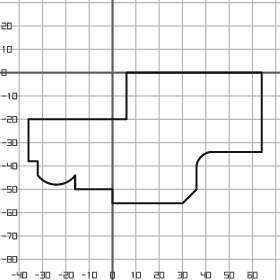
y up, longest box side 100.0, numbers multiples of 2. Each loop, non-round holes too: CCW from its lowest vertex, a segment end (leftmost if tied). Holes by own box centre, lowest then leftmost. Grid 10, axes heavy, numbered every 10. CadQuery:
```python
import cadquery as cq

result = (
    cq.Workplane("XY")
    .moveTo(0.0, -56.0)
    .lineTo(30.0, -56.0)
    .lineTo(36.0, -50.0)
    .lineTo(36.0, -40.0)
    .threePointArc((38.0, -36.0), (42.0, -34.0))
    .lineTo(64.0, -34.0)
    .lineTo(64.0, 0.0)
    .lineTo(6.0, 0.0)
    .lineTo(6.0, -20.0)
    .lineTo(-36.0, -20.0)
    .lineTo(-36.0, -38.0)
    .lineTo(-32.0, -38.0)
    .lineTo(-32.0, -44.0)
    .threePointArc((-24.0, -48.0), (-16.0, -44.0))
    .lineTo(-16.0, -50.0)
    .lineTo(0.0, -50.0)
    .close()
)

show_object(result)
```